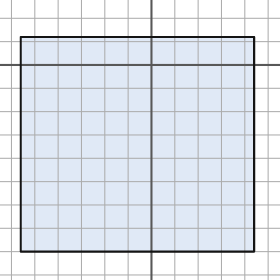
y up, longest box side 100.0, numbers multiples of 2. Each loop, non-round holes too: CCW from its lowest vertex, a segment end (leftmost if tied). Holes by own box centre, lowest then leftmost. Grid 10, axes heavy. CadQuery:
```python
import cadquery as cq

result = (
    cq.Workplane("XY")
    .moveTo(-56.0, -80.0)
    .lineTo(44.0, -80.0)
    .lineTo(44.0, 12.0)
    .lineTo(-56.0, 12.0)
    .close()
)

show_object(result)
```